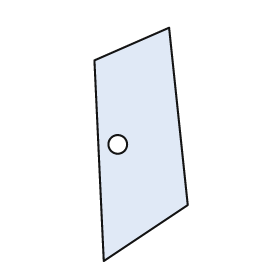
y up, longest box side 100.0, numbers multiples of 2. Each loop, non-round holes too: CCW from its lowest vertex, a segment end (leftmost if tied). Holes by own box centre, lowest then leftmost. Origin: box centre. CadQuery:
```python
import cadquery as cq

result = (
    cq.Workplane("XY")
    .moveTo(-16.0, -50.0)
    .lineTo(20.0, -26.0)
    .lineTo(12.0, 50.0)
    .lineTo(-20.0, 36.0)
    .close()
    .moveTo(-10.0, 0.0)
    .circle(4.0)
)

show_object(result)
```